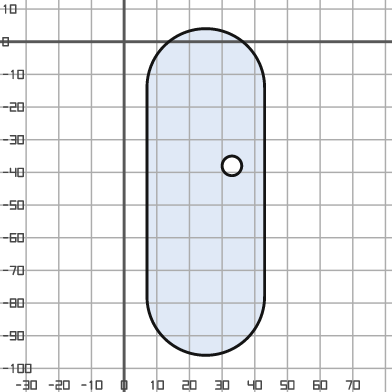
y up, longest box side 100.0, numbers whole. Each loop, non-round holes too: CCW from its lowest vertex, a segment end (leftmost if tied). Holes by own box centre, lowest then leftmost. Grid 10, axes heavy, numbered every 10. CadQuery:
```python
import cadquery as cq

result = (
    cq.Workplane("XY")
    .moveTo(7.0, -78.0)
    .threePointArc((25.0, -96.0), (43.0, -78.0))
    .lineTo(43.0, -14.0)
    .threePointArc((25.0, 4.0), (7.0, -14.0))
    .close()
    .moveTo(33.0, -38.0)
    .circle(3.0)
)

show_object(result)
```